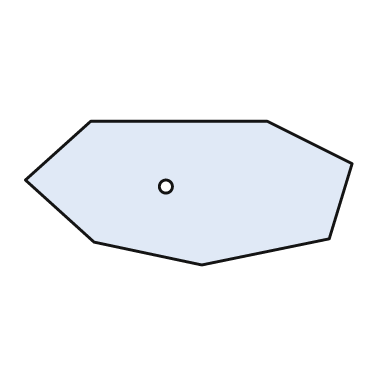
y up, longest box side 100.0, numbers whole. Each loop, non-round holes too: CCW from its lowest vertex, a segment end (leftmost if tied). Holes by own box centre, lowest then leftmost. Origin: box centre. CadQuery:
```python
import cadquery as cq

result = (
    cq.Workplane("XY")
    .moveTo(4.0, -22.0)
    .lineTo(43.0, -14.0)
    .lineTo(50.0, 9.0)
    .lineTo(24.0, 22.0)
    .lineTo(-30.0, 22.0)
    .lineTo(-50.0, 4.0)
    .lineTo(-29.0, -15.0)
    .close()
    .moveTo(-7.0, 2.0)
    .circle(2.0)
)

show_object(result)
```